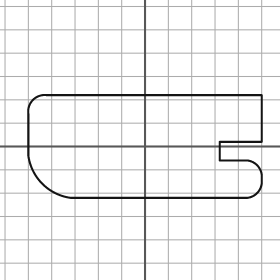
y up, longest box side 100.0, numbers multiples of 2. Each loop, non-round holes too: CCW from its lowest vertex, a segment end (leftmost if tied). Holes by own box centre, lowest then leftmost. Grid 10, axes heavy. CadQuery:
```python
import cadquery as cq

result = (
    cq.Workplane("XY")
    .moveTo(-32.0, -22.0)
    .lineTo(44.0, -22.0)
    .threePointArc((48.0, -20.0), (50.0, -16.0))
    .lineTo(50.0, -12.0)
    .threePointArc((48.0, -8.0), (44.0, -6.0))
    .lineTo(32.0, -6.0)
    .lineTo(32.0, 2.0)
    .lineTo(50.0, 2.0)
    .lineTo(50.0, 22.0)
    .lineTo(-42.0, 22.0)
    .threePointArc((-48.0, 20.0), (-50.0, 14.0))
    .lineTo(-50.0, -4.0)
    .threePointArc((-44.0, -16.0), (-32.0, -22.0))
    .close()
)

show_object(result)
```